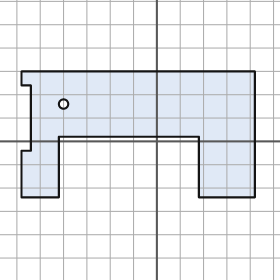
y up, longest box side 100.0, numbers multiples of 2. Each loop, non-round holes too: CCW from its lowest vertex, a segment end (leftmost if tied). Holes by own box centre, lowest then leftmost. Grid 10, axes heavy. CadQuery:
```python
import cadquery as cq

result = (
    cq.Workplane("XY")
    .moveTo(-58.0, -24.0)
    .lineTo(-42.0, -24.0)
    .lineTo(-42.0, 2.0)
    .lineTo(18.0, 2.0)
    .lineTo(18.0, -24.0)
    .lineTo(42.0, -24.0)
    .lineTo(42.0, 30.0)
    .lineTo(-58.0, 30.0)
    .lineTo(-58.0, 24.0)
    .lineTo(-54.0, 24.0)
    .lineTo(-54.0, -4.0)
    .lineTo(-58.0, -4.0)
    .close()
    .moveTo(-40.0, 16.0)
    .circle(2.0)
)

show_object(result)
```